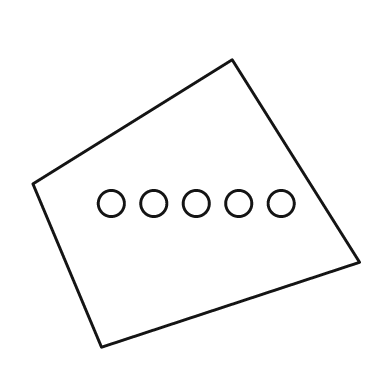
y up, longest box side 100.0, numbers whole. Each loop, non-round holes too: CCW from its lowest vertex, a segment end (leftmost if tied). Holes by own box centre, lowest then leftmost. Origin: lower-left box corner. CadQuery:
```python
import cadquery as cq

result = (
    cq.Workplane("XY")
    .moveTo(21.0, 0.0)
    .lineTo(100.0, 26.0)
    .lineTo(61.0, 88.0)
    .lineTo(0.0, 50.0)
    .close()
    .moveTo(24.0, 44.0)
    .circle(4.0)
    .moveTo(37.0, 44.0)
    .circle(4.0)
    .moveTo(50.0, 44.0)
    .circle(4.0)
    .moveTo(63.0, 44.0)
    .circle(4.0)
    .moveTo(76.0, 44.0)
    .circle(4.0)
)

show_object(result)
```